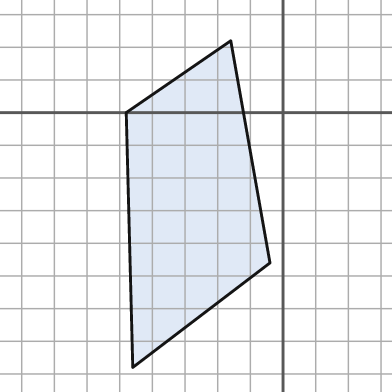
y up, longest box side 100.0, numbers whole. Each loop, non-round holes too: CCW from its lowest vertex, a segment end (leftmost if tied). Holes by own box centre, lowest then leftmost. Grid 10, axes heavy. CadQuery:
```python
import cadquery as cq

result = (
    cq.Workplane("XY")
    .moveTo(-46.0, -78.0)
    .lineTo(-4.0, -46.0)
    .lineTo(-16.0, 22.0)
    .lineTo(-48.0, 0.0)
    .close()
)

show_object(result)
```